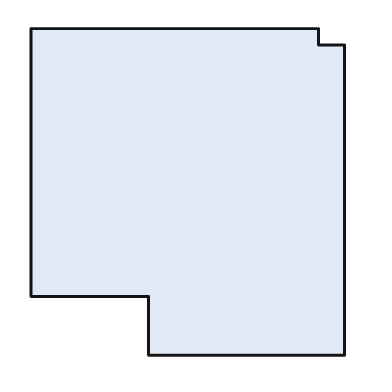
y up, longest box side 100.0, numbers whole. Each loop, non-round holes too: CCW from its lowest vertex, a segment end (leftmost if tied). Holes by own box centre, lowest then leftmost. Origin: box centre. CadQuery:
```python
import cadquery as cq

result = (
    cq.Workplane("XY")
    .moveTo(-12.0, -50.0)
    .lineTo(48.0, -50.0)
    .lineTo(48.0, 45.0)
    .lineTo(40.0, 45.0)
    .lineTo(40.0, 50.0)
    .lineTo(-48.0, 50.0)
    .lineTo(-48.0, -32.0)
    .lineTo(-12.0, -32.0)
    .close()
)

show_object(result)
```